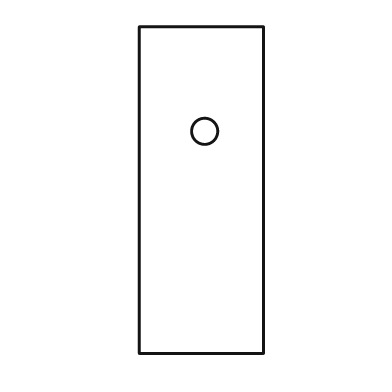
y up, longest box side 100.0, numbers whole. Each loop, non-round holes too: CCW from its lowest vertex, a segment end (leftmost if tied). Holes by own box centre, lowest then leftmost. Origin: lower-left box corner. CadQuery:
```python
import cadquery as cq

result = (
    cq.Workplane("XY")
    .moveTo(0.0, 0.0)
    .lineTo(38.0, 0.0)
    .lineTo(38.0, 100.0)
    .lineTo(0.0, 100.0)
    .close()
    .moveTo(20.0, 68.0)
    .circle(4.0)
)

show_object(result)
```